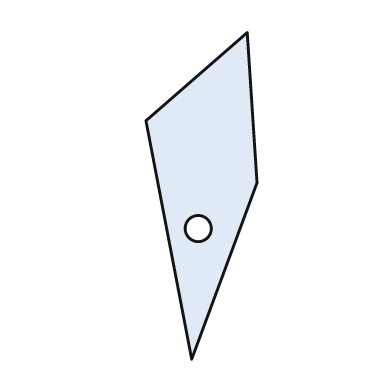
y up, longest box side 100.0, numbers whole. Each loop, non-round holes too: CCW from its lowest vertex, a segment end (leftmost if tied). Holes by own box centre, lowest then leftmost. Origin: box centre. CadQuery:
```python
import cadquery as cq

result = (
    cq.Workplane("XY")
    .moveTo(-3.0, -50.0)
    .lineTo(17.0, 4.0)
    .lineTo(14.0, 50.0)
    .lineTo(-17.0, 23.0)
    .close()
    .moveTo(-1.0, -10.0)
    .circle(4.0)
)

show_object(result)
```